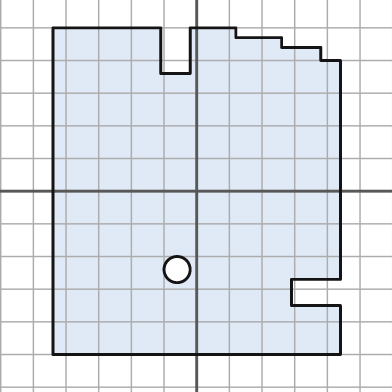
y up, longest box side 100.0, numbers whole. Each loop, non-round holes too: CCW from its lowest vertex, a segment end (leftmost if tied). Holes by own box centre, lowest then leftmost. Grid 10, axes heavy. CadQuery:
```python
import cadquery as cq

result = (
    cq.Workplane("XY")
    .moveTo(-44.0, -50.0)
    .lineTo(44.0, -50.0)
    .lineTo(44.0, -35.0)
    .lineTo(29.0, -35.0)
    .lineTo(29.0, -27.0)
    .lineTo(44.0, -27.0)
    .lineTo(44.0, 40.0)
    .lineTo(38.0, 40.0)
    .lineTo(38.0, 44.0)
    .lineTo(26.0, 44.0)
    .lineTo(26.0, 47.0)
    .lineTo(12.0, 47.0)
    .lineTo(12.0, 50.0)
    .lineTo(-2.0, 50.0)
    .lineTo(-2.0, 36.0)
    .lineTo(-11.0, 36.0)
    .lineTo(-11.0, 50.0)
    .lineTo(-44.0, 50.0)
    .close()
    .moveTo(-6.0, -24.0)
    .circle(4.0)
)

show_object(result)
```